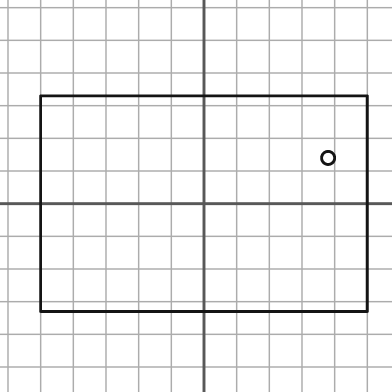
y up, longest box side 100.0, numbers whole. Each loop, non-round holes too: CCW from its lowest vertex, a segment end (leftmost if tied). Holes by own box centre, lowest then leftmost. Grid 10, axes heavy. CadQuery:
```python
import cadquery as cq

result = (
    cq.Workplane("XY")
    .moveTo(-50.0, -33.0)
    .lineTo(50.0, -33.0)
    .lineTo(50.0, 33.0)
    .lineTo(-50.0, 33.0)
    .close()
    .moveTo(38.0, 14.0)
    .circle(2.0)
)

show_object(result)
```